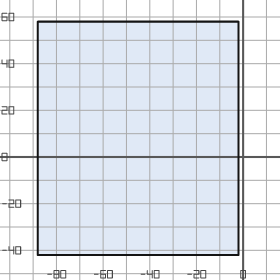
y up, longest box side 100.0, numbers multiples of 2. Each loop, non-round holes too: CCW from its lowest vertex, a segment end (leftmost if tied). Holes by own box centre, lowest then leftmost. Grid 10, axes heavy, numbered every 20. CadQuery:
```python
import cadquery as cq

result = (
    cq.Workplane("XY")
    .moveTo(-88.0, -42.0)
    .lineTo(-2.0, -42.0)
    .lineTo(-2.0, 58.0)
    .lineTo(-88.0, 58.0)
    .close()
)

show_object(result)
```